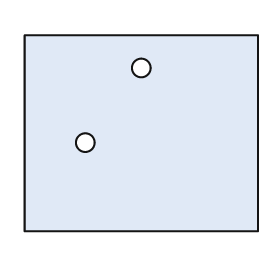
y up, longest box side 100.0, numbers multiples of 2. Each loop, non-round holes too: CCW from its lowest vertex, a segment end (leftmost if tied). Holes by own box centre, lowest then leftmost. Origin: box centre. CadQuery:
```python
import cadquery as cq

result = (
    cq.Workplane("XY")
    .moveTo(-50.0, -42.0)
    .lineTo(50.0, -42.0)
    .lineTo(50.0, 42.0)
    .lineTo(-50.0, 42.0)
    .close()
    .moveTo(-24.0, -4.0)
    .circle(4.0)
    .moveTo(0.0, 28.0)
    .circle(4.0)
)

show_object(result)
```